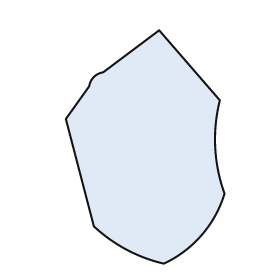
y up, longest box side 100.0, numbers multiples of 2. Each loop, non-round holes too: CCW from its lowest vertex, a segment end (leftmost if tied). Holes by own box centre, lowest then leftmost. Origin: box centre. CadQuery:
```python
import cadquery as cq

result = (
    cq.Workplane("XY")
    .moveTo(8.0, -50.0)
    .threePointArc((24.0, -38.0), (34.0, -20.0))
    .threePointArc((30.0, 0.0), (32.0, 20.0))
    .lineTo(6.0, 50.0)
    .lineTo(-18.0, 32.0)
    .threePointArc((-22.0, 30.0), (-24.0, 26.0))
    .lineTo(-34.0, 12.0)
    .lineTo(-22.0, -34.0)
    .threePointArc((-8.0, -44.0), (8.0, -50.0))
    .close()
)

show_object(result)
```